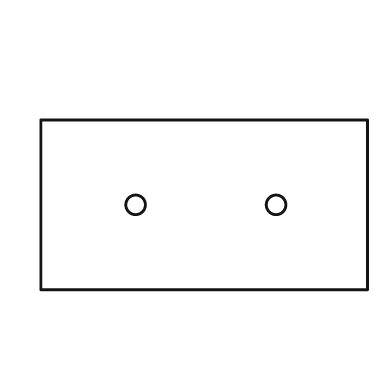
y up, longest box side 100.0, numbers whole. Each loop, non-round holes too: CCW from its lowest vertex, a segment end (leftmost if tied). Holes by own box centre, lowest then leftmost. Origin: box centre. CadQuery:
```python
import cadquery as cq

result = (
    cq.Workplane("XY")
    .moveTo(-50.0, -26.0)
    .lineTo(50.0, -26.0)
    .lineTo(50.0, 26.0)
    .lineTo(-50.0, 26.0)
    .close()
    .moveTo(-21.0, 0.0)
    .circle(3.0)
    .moveTo(22.0, 0.0)
    .circle(3.0)
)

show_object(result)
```